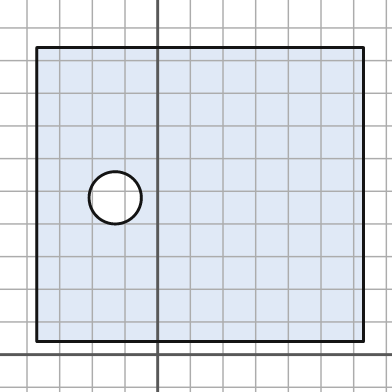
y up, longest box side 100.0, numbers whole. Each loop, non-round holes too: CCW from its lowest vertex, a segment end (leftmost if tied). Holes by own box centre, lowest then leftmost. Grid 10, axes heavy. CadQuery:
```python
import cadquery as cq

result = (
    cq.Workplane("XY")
    .moveTo(-37.0, 4.0)
    .lineTo(63.0, 4.0)
    .lineTo(63.0, 94.0)
    .lineTo(-37.0, 94.0)
    .close()
    .moveTo(-13.0, 48.0)
    .circle(8.0)
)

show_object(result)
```